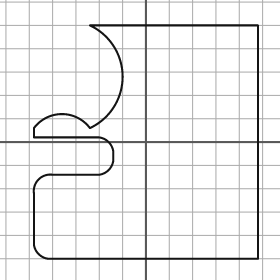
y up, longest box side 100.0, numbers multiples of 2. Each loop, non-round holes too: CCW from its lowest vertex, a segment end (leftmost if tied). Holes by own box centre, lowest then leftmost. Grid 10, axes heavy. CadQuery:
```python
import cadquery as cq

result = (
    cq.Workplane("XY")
    .moveTo(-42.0, -50.0)
    .lineTo(48.0, -50.0)
    .lineTo(48.0, 50.0)
    .lineTo(-24.0, 50.0)
    .threePointArc((-10.0, 28.0), (-24.0, 6.0))
    .threePointArc((-36.0, 12.0), (-48.0, 6.0))
    .lineTo(-48.0, 2.0)
    .lineTo(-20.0, 2.0)
    .threePointArc((-16.0, 0.0), (-14.0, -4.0))
    .lineTo(-14.0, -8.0)
    .threePointArc((-16.0, -12.0), (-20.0, -14.0))
    .lineTo(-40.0, -14.0)
    .threePointArc((-46.0, -16.0), (-48.0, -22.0))
    .lineTo(-48.0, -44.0)
    .threePointArc((-46.0, -48.0), (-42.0, -50.0))
    .close()
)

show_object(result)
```